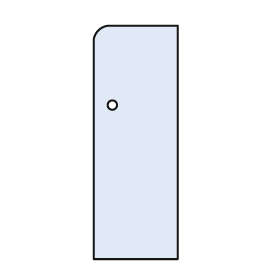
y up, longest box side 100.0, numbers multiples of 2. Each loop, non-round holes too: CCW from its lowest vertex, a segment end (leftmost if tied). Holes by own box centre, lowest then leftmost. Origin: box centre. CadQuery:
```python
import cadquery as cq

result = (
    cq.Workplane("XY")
    .moveTo(-18.0, -50.0)
    .lineTo(18.0, -50.0)
    .lineTo(18.0, 50.0)
    .lineTo(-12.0, 50.0)
    .threePointArc((-16.0, 48.0), (-18.0, 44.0))
    .close()
    .moveTo(-10.0, 16.0)
    .circle(2.0)
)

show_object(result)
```